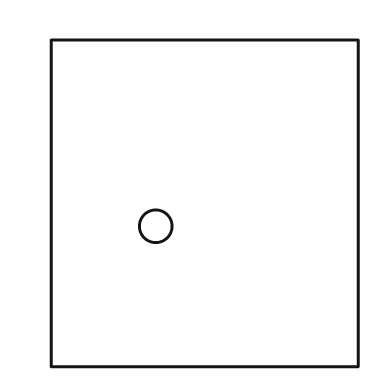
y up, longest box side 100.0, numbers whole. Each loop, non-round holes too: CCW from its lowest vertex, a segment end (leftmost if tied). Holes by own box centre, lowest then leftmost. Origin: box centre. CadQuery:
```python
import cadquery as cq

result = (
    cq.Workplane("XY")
    .moveTo(-47.0, -50.0)
    .lineTo(47.0, -50.0)
    .lineTo(47.0, 50.0)
    .lineTo(-47.0, 50.0)
    .close()
    .moveTo(-15.0, -7.0)
    .circle(5.0)
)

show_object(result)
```